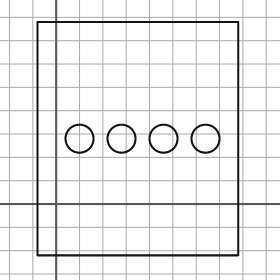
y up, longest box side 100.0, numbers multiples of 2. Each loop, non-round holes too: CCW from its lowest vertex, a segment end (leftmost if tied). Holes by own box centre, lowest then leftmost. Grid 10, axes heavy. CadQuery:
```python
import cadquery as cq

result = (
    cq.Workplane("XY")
    .moveTo(-8.0, -22.0)
    .lineTo(78.0, -22.0)
    .lineTo(78.0, 78.0)
    .lineTo(-8.0, 78.0)
    .close()
    .moveTo(10.0, 28.0)
    .circle(6.0)
    .moveTo(28.0, 28.0)
    .circle(6.0)
    .moveTo(46.0, 28.0)
    .circle(6.0)
    .moveTo(64.0, 28.0)
    .circle(6.0)
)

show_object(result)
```